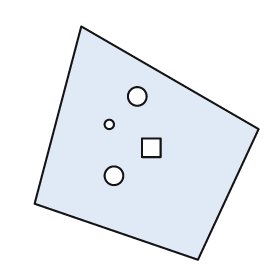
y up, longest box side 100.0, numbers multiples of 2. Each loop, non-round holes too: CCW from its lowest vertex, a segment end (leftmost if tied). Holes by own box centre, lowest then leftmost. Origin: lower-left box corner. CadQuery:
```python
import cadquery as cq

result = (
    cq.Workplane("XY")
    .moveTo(70.0, 0.0)
    .lineTo(96.0, 56.0)
    .lineTo(20.0, 100.0)
    .lineTo(0.0, 24.0)
    .close()
    .moveTo(34.0, 36.0)
    .circle(4.0)
    .moveTo(46.0, 44.0)
    .lineTo(54.0, 44.0)
    .lineTo(54.0, 52.0)
    .lineTo(46.0, 52.0)
    .close()
    .moveTo(32.0, 58.0)
    .circle(2.0)
    .moveTo(44.0, 70.0)
    .circle(4.0)
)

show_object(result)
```